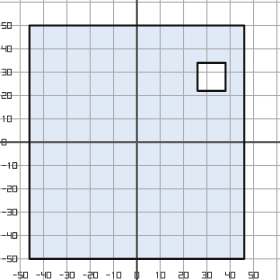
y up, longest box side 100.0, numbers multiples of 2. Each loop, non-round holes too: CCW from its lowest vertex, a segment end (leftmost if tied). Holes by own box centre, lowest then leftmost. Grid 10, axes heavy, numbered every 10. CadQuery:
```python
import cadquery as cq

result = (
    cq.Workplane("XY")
    .moveTo(-46.0, -50.0)
    .lineTo(46.0, -50.0)
    .lineTo(46.0, 50.0)
    .lineTo(-46.0, 50.0)
    .close()
    .moveTo(26.0, 22.0)
    .lineTo(38.0, 22.0)
    .lineTo(38.0, 34.0)
    .lineTo(26.0, 34.0)
    .close()
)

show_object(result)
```